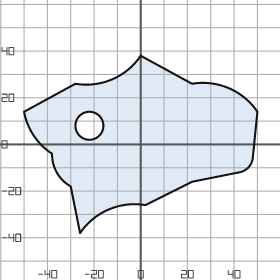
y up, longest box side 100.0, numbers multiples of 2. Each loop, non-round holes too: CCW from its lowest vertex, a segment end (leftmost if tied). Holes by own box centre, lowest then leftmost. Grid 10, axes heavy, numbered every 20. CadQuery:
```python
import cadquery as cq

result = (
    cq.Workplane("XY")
    .moveTo(-26.0, -38.0)
    .threePointArc((-14.0, -28.0), (2.0, -26.0))
    .lineTo(22.0, -16.0)
    .lineTo(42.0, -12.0)
    .threePointArc((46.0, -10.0), (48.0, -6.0))
    .lineTo(50.0, 14.0)
    .threePointArc((38.0, 24.0), (22.0, 26.0))
    .lineTo(0.0, 38.0)
    .threePointArc((-12.0, 28.0), (-28.0, 26.0))
    .lineTo(-50.0, 14.0)
    .threePointArc((-46.0, 4.0), (-38.0, -4.0))
    .threePointArc((-36.0, -12.0), (-30.0, -18.0))
    .close()
    .moveTo(-22.0, 8.0)
    .circle(6.0)
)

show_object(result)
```